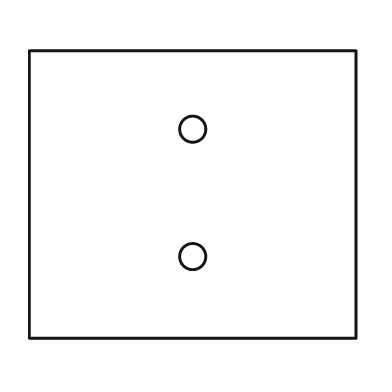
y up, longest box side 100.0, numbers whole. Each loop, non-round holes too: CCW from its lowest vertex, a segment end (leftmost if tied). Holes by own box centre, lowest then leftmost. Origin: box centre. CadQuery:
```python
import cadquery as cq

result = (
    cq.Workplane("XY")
    .moveTo(-50.0, -44.0)
    .lineTo(50.0, -44.0)
    .lineTo(50.0, 44.0)
    .lineTo(-50.0, 44.0)
    .close()
    .moveTo(0.0, -19.0)
    .circle(4.0)
    .moveTo(0.0, 20.0)
    .circle(4.0)
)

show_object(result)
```